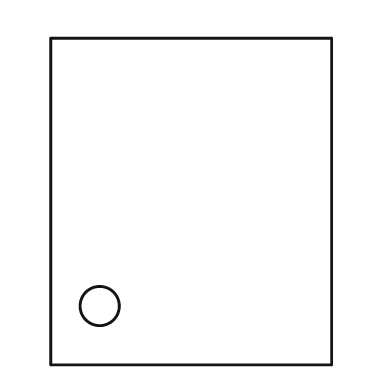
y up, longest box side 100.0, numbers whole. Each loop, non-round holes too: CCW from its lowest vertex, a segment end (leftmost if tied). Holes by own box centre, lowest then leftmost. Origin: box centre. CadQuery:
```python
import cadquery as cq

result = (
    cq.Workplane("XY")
    .moveTo(-43.0, -50.0)
    .lineTo(43.0, -50.0)
    .lineTo(43.0, 50.0)
    .lineTo(-43.0, 50.0)
    .close()
    .moveTo(-28.0, -32.0)
    .circle(6.0)
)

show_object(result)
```